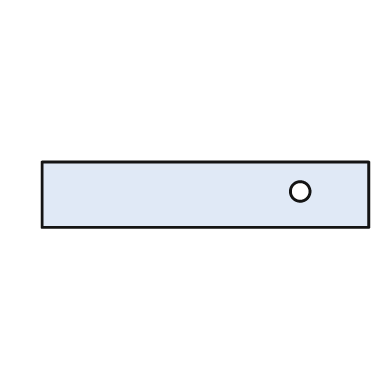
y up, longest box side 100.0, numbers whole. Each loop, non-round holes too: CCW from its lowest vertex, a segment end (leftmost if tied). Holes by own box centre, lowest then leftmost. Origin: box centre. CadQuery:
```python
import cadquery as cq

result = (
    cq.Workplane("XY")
    .moveTo(-50.0, -10.0)
    .lineTo(50.0, -10.0)
    .lineTo(50.0, 10.0)
    .lineTo(-50.0, 10.0)
    .close()
    .moveTo(29.0, 1.0)
    .circle(3.0)
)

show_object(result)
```